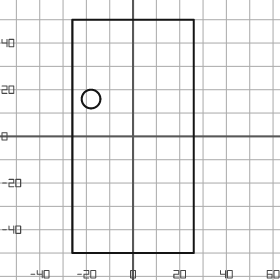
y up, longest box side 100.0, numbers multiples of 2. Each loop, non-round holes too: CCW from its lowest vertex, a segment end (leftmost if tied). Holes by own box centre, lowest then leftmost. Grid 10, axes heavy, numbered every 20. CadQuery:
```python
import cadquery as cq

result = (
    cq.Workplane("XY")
    .moveTo(-26.0, -50.0)
    .lineTo(26.0, -50.0)
    .lineTo(26.0, 50.0)
    .lineTo(-26.0, 50.0)
    .close()
    .moveTo(-18.0, 16.0)
    .circle(4.0)
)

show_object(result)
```